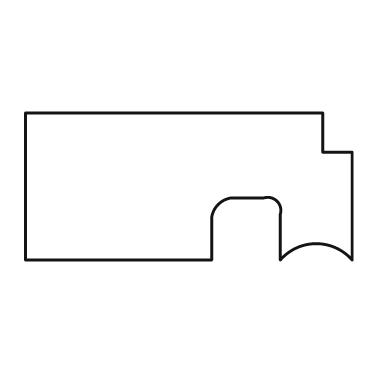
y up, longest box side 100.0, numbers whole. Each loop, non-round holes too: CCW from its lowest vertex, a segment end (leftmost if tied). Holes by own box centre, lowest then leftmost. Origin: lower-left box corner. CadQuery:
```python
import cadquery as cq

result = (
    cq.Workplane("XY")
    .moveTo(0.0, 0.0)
    .lineTo(57.0, 0.0)
    .lineTo(57.0, 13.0)
    .threePointArc((59.0, 17.0), (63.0, 19.0))
    .lineTo(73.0, 19.0)
    .threePointArc((77.0, 18.0), (78.0, 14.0))
    .lineTo(78.0, 0.0)
    .threePointArc((89.0, 5.0), (100.0, 0.0))
    .lineTo(100.0, 33.0)
    .lineTo(91.0, 33.0)
    .lineTo(91.0, 45.0)
    .lineTo(0.0, 45.0)
    .close()
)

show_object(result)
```